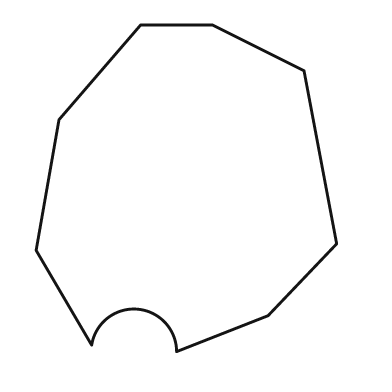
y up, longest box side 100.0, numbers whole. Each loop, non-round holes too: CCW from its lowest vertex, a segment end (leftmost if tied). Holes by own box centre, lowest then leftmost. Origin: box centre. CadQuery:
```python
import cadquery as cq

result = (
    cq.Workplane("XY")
    .moveTo(-3.0, -50.0)
    .lineTo(25.0, -39.0)
    .lineTo(46.0, -17.0)
    .lineTo(36.0, 36.0)
    .lineTo(8.0, 50.0)
    .lineTo(-14.0, 50.0)
    .lineTo(-39.0, 21.0)
    .lineTo(-46.0, -19.0)
    .lineTo(-29.0, -48.0)
    .threePointArc((-15.0, -37.0), (-3.0, -50.0))
    .close()
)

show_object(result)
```